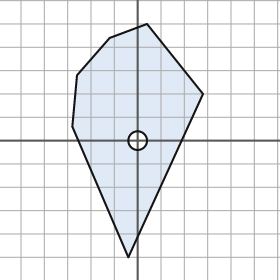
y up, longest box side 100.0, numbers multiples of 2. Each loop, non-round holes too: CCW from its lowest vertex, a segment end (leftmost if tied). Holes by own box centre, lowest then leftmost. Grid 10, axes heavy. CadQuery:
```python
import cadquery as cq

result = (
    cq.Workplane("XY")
    .moveTo(-4.0, -50.0)
    .lineTo(28.0, 20.0)
    .lineTo(4.0, 50.0)
    .lineTo(-12.0, 44.0)
    .lineTo(-26.0, 28.0)
    .lineTo(-28.0, 6.0)
    .close()
    .moveTo(0.0, 0.0)
    .circle(4.0)
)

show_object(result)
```